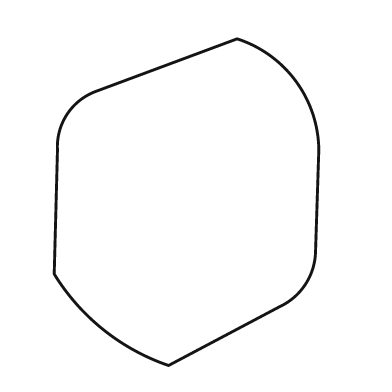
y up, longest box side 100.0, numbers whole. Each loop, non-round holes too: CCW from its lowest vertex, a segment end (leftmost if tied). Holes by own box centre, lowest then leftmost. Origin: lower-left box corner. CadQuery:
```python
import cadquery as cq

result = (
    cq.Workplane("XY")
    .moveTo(35.0, 0.0)
    .lineTo(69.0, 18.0)
    .threePointArc((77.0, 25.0), (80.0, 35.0))
    .lineTo(81.0, 66.0)
    .threePointArc((74.0, 87.0), (56.0, 100.0))
    .lineTo(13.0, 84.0)
    .threePointArc((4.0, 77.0), (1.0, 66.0))
    .lineTo(0.0, 28.0)
    .threePointArc((15.0, 11.0), (35.0, 0.0))
    .close()
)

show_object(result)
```